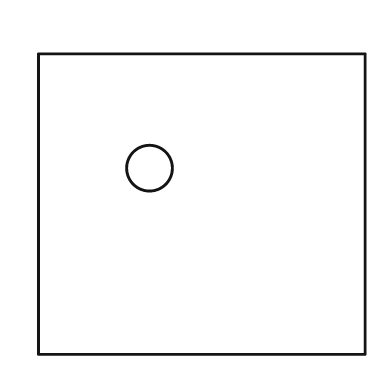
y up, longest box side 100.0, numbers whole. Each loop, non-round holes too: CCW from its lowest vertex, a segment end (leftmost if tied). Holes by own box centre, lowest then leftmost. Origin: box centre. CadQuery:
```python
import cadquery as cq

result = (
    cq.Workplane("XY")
    .moveTo(-50.0, -46.0)
    .lineTo(50.0, -46.0)
    .lineTo(50.0, 46.0)
    .lineTo(-50.0, 46.0)
    .close()
    .moveTo(-16.0, 11.0)
    .circle(7.0)
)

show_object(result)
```